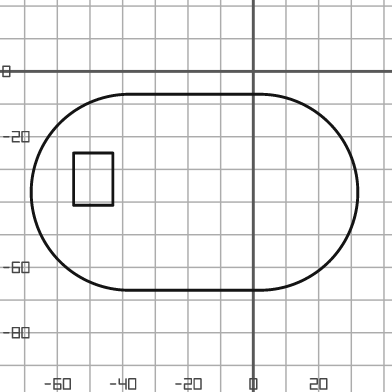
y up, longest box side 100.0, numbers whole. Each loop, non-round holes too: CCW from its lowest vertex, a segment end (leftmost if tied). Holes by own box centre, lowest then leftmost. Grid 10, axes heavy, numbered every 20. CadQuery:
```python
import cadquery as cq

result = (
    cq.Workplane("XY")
    .moveTo(-38.0, -67.0)
    .lineTo(2.0, -67.0)
    .threePointArc((32.0, -37.0), (2.0, -7.0))
    .lineTo(-38.0, -7.0)
    .threePointArc((-68.0, -37.0), (-38.0, -67.0))
    .close()
    .moveTo(-55.0, -41.0)
    .lineTo(-43.0, -41.0)
    .lineTo(-43.0, -25.0)
    .lineTo(-55.0, -25.0)
    .close()
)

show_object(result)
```